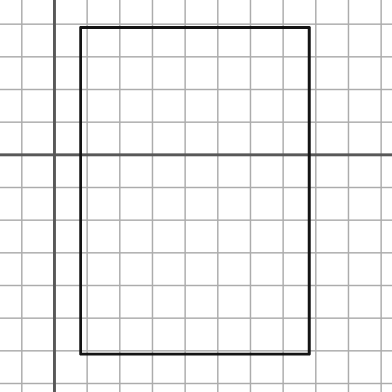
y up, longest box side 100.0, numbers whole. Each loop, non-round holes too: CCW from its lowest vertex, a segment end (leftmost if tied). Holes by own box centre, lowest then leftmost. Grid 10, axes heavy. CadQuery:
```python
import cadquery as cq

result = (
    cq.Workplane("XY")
    .moveTo(8.0, -61.0)
    .lineTo(78.0, -61.0)
    .lineTo(78.0, 39.0)
    .lineTo(8.0, 39.0)
    .close()
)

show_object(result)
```